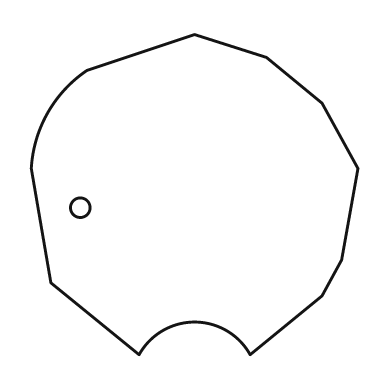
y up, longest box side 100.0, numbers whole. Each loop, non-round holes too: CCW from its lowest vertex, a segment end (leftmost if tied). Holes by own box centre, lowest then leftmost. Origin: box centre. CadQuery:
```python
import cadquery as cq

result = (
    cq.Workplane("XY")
    .moveTo(-17.0, -49.0)
    .threePointArc((0.0, -39.0), (17.0, -49.0))
    .lineTo(39.0, -31.0)
    .lineTo(45.0, -20.0)
    .lineTo(50.0, 8.0)
    .lineTo(39.0, 28.0)
    .lineTo(22.0, 42.0)
    .lineTo(0.0, 49.0)
    .lineTo(-33.0, 38.0)
    .threePointArc((-45.0, 25.0), (-50.0, 8.0))
    .lineTo(-44.0, -27.0)
    .close()
    .moveTo(-35.0, -4.0)
    .circle(3.0)
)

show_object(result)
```